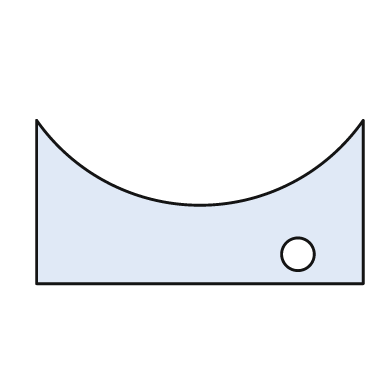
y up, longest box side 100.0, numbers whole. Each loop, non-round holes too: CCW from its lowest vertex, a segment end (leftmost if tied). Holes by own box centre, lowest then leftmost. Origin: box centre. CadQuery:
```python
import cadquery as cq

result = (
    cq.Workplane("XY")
    .moveTo(-50.0, -25.0)
    .lineTo(50.0, -25.0)
    .lineTo(50.0, 25.0)
    .threePointArc((0.0, -1.0), (-50.0, 25.0))
    .close()
    .moveTo(30.0, -16.0)
    .circle(5.0)
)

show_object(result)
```